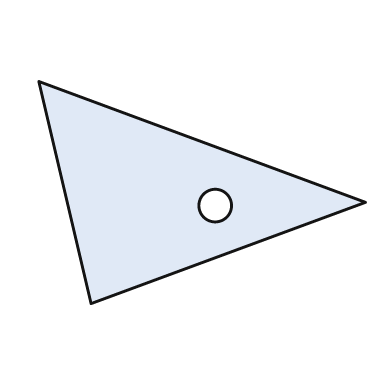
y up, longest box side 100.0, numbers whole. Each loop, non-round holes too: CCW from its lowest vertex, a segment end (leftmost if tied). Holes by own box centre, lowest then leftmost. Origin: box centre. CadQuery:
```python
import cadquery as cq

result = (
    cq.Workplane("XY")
    .moveTo(-34.0, -34.0)
    .lineTo(50.0, -3.0)
    .lineTo(-50.0, 34.0)
    .close()
    .moveTo(4.0, -4.0)
    .circle(5.0)
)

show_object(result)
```